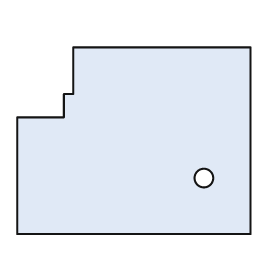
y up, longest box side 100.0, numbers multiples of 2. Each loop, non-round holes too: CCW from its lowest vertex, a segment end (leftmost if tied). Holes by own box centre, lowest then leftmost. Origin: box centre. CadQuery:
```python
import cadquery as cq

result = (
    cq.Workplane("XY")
    .moveTo(-50.0, -40.0)
    .lineTo(50.0, -40.0)
    .lineTo(50.0, 40.0)
    .lineTo(-26.0, 40.0)
    .lineTo(-26.0, 20.0)
    .lineTo(-30.0, 20.0)
    .lineTo(-30.0, 10.0)
    .lineTo(-50.0, 10.0)
    .close()
    .moveTo(30.0, -16.0)
    .circle(4.0)
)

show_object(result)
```